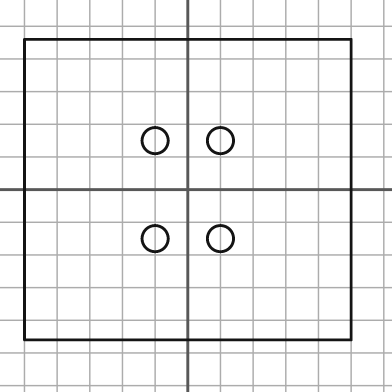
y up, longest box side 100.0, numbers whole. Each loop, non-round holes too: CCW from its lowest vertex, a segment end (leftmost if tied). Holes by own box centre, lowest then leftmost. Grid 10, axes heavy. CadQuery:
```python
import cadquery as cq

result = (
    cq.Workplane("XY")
    .moveTo(-50.0, -46.0)
    .lineTo(50.0, -46.0)
    .lineTo(50.0, 46.0)
    .lineTo(-50.0, 46.0)
    .close()
    .moveTo(-10.0, -15.0)
    .circle(4.0)
    .moveTo(10.0, -15.0)
    .circle(4.0)
    .moveTo(-10.0, 15.0)
    .circle(4.0)
    .moveTo(10.0, 15.0)
    .circle(4.0)
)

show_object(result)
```